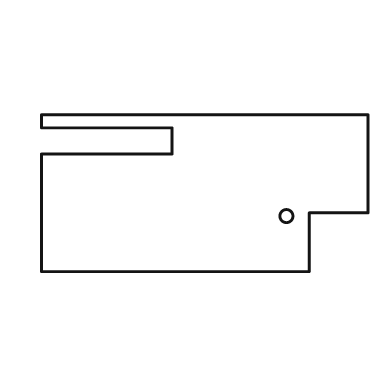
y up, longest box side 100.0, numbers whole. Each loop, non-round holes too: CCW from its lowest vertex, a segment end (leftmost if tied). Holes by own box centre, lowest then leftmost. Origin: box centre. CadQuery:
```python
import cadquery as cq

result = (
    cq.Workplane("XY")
    .moveTo(-50.0, -24.0)
    .lineTo(32.0, -24.0)
    .lineTo(32.0, -6.0)
    .lineTo(50.0, -6.0)
    .lineTo(50.0, 24.0)
    .lineTo(-50.0, 24.0)
    .lineTo(-50.0, 20.0)
    .lineTo(-10.0, 20.0)
    .lineTo(-10.0, 12.0)
    .lineTo(-50.0, 12.0)
    .close()
    .moveTo(25.0, -7.0)
    .circle(2.0)
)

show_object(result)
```